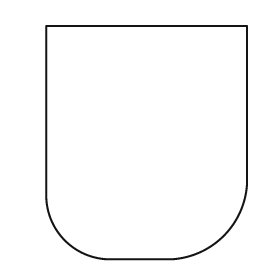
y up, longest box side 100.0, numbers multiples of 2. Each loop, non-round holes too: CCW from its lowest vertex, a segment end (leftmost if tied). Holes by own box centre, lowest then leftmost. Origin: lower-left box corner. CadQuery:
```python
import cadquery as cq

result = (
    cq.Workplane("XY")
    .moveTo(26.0, 0.0)
    .lineTo(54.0, 0.0)
    .threePointArc((76.0, 10.0), (86.0, 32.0))
    .lineTo(86.0, 100.0)
    .lineTo(0.0, 100.0)
    .lineTo(0.0, 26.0)
    .threePointArc((8.0, 8.0), (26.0, 0.0))
    .close()
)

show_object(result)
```